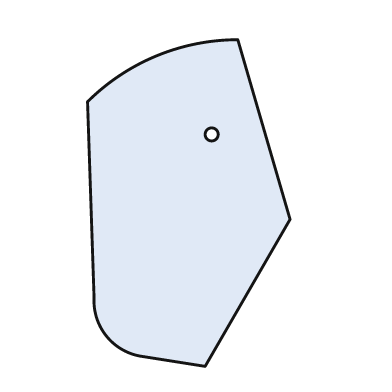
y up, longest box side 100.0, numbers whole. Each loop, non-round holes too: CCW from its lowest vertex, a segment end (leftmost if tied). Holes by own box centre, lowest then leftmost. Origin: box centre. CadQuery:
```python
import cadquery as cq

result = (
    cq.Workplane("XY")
    .moveTo(5.0, -50.0)
    .lineTo(31.0, -5.0)
    .lineTo(15.0, 50.0)
    .threePointArc((-10.0, 45.0), (-31.0, 31.0))
    .lineTo(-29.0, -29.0)
    .threePointArc((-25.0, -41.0), (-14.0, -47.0))
    .close()
    .moveTo(7.0, 21.0)
    .circle(2.0)
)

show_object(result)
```